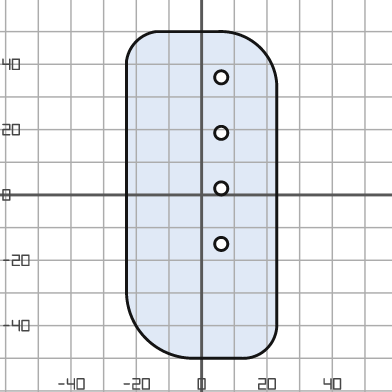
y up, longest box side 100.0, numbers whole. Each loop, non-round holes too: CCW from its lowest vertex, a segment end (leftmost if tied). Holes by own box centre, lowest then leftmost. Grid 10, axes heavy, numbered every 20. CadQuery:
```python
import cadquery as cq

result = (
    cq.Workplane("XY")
    .moveTo(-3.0, -50.0)
    .lineTo(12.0, -50.0)
    .threePointArc((20.0, -47.0), (23.0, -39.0))
    .lineTo(23.0, 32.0)
    .threePointArc((18.0, 45.0), (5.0, 50.0))
    .lineTo(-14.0, 50.0)
    .threePointArc((-20.0, 47.0), (-23.0, 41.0))
    .lineTo(-23.0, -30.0)
    .threePointArc((-17.0, -44.0), (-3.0, -50.0))
    .close()
    .moveTo(6.0, -15.0)
    .circle(2.0)
    .moveTo(6.0, 2.0)
    .circle(2.0)
    .moveTo(6.0, 19.0)
    .circle(2.0)
    .moveTo(6.0, 36.0)
    .circle(2.0)
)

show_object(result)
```